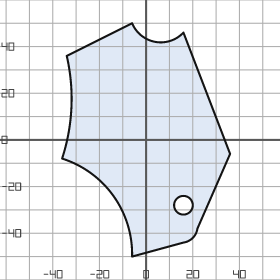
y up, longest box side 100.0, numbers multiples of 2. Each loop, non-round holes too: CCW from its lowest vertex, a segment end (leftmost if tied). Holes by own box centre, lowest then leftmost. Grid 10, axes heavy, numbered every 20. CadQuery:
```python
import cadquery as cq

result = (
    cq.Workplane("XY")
    .moveTo(-6.0, -50.0)
    .lineTo(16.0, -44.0)
    .threePointArc((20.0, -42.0), (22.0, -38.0))
    .lineTo(36.0, -6.0)
    .lineTo(16.0, 46.0)
    .threePointArc((4.0, 42.0), (-6.0, 50.0))
    .lineTo(-34.0, 36.0)
    .threePointArc((-32.0, 14.0), (-36.0, -8.0))
    .threePointArc((-14.0, -24.0), (-6.0, -50.0))
    .close()
    .moveTo(16.0, -28.0)
    .circle(4.0)
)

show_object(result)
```